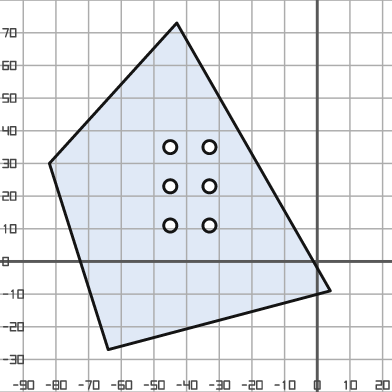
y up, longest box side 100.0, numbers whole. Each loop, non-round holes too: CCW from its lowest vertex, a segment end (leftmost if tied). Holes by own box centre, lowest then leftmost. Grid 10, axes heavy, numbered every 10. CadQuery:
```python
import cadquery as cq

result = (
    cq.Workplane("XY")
    .moveTo(-64.0, -27.0)
    .lineTo(4.0, -9.0)
    .lineTo(-43.0, 73.0)
    .lineTo(-82.0, 30.0)
    .close()
    .moveTo(-45.0, 11.0)
    .circle(2.0)
    .moveTo(-33.0, 11.0)
    .circle(2.0)
    .moveTo(-45.0, 23.0)
    .circle(2.0)
    .moveTo(-33.0, 23.0)
    .circle(2.0)
    .moveTo(-45.0, 35.0)
    .circle(2.0)
    .moveTo(-33.0, 35.0)
    .circle(2.0)
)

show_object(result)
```